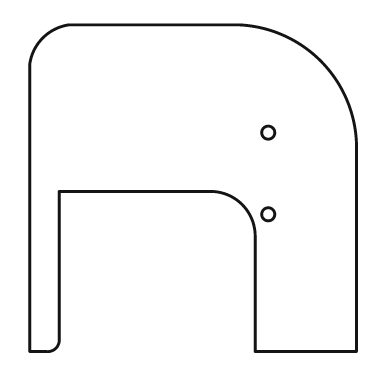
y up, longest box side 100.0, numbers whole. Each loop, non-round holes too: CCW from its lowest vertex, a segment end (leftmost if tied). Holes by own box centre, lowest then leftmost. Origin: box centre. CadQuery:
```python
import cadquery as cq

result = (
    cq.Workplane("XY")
    .moveTo(-50.0, -50.0)
    .lineTo(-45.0, -50.0)
    .threePointArc((-42.0, -49.0), (-41.0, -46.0))
    .lineTo(-41.0, -1.0)
    .lineTo(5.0, -1.0)
    .threePointArc((15.0, -5.0), (19.0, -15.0))
    .lineTo(19.0, -50.0)
    .lineTo(50.0, -50.0)
    .lineTo(50.0, 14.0)
    .threePointArc((39.0, 39.0), (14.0, 50.0))
    .lineTo(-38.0, 50.0)
    .threePointArc((-46.0, 46.0), (-50.0, 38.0))
    .close()
    .moveTo(23.0, -8.0)
    .circle(2.0)
    .moveTo(23.0, 17.0)
    .circle(2.0)
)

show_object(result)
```